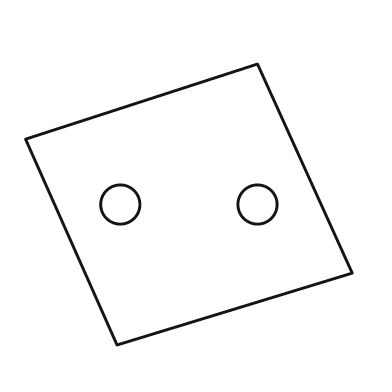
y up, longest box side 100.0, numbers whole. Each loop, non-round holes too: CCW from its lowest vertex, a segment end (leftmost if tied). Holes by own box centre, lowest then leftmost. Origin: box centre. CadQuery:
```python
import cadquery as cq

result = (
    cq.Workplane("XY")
    .moveTo(-22.0, -43.0)
    .lineTo(50.0, -21.0)
    .lineTo(21.0, 43.0)
    .lineTo(-50.0, 20.0)
    .close()
    .moveTo(-21.0, 0.0)
    .circle(6.0)
    .moveTo(21.0, 0.0)
    .circle(6.0)
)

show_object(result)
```